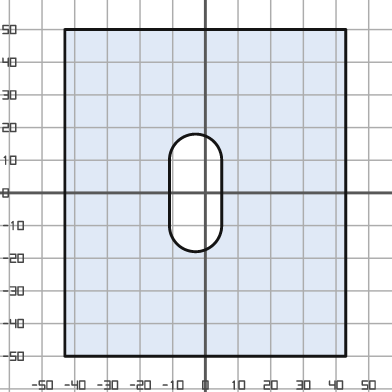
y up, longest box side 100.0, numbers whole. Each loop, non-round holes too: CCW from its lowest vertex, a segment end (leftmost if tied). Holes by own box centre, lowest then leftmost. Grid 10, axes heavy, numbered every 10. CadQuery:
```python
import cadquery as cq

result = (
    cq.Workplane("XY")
    .moveTo(-43.0, -50.0)
    .lineTo(43.0, -50.0)
    .lineTo(43.0, 50.0)
    .lineTo(-43.0, 50.0)
    .close()
    .moveTo(-11.0, -10.0)
    .threePointArc((-3.0, -18.0), (5.0, -10.0))
    .lineTo(5.0, 10.0)
    .threePointArc((-3.0, 18.0), (-11.0, 10.0))
    .close()
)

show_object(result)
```